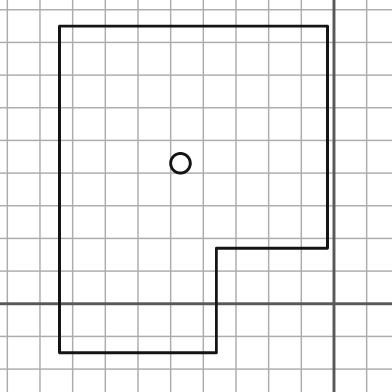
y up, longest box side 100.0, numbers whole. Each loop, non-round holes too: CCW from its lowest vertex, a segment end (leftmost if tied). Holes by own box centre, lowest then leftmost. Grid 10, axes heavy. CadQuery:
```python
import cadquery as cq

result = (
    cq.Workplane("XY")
    .moveTo(-84.0, -15.0)
    .lineTo(-36.0, -15.0)
    .lineTo(-36.0, 17.0)
    .lineTo(-2.0, 17.0)
    .lineTo(-2.0, 85.0)
    .lineTo(-84.0, 85.0)
    .close()
    .moveTo(-47.0, 43.0)
    .circle(3.0)
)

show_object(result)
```